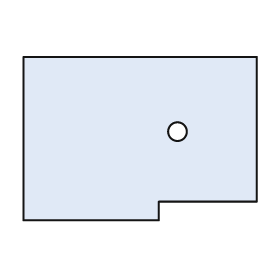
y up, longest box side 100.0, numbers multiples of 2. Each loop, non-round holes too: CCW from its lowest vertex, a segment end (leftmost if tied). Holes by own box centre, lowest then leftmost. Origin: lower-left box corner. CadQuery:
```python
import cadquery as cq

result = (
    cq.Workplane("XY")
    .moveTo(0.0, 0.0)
    .lineTo(58.0, 0.0)
    .lineTo(58.0, 8.0)
    .lineTo(100.0, 8.0)
    .lineTo(100.0, 70.0)
    .lineTo(0.0, 70.0)
    .close()
    .moveTo(66.0, 38.0)
    .circle(4.0)
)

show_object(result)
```